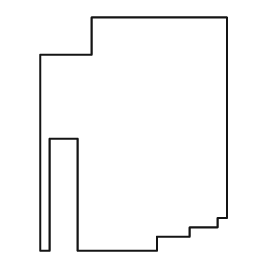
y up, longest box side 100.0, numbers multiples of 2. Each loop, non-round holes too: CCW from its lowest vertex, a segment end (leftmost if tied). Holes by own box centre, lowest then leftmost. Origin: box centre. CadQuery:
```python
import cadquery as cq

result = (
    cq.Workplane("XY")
    .moveTo(-40.0, -50.0)
    .lineTo(-36.0, -50.0)
    .lineTo(-36.0, -2.0)
    .lineTo(-24.0, -2.0)
    .lineTo(-24.0, -50.0)
    .lineTo(10.0, -50.0)
    .lineTo(10.0, -44.0)
    .lineTo(24.0, -44.0)
    .lineTo(24.0, -40.0)
    .lineTo(36.0, -40.0)
    .lineTo(36.0, -36.0)
    .lineTo(40.0, -36.0)
    .lineTo(40.0, 50.0)
    .lineTo(-18.0, 50.0)
    .lineTo(-18.0, 34.0)
    .lineTo(-40.0, 34.0)
    .close()
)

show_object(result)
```